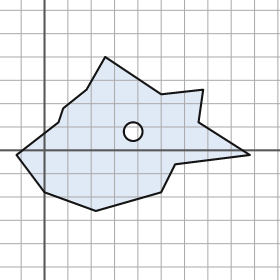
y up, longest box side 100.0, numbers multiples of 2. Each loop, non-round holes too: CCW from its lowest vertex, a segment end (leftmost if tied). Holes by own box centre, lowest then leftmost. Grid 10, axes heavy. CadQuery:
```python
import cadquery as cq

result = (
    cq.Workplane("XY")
    .moveTo(22.0, -26.0)
    .lineTo(50.0, -18.0)
    .lineTo(56.0, -6.0)
    .lineTo(88.0, -2.0)
    .lineTo(66.0, 12.0)
    .lineTo(68.0, 26.0)
    .lineTo(50.0, 24.0)
    .lineTo(26.0, 40.0)
    .lineTo(18.0, 26.0)
    .lineTo(8.0, 18.0)
    .lineTo(6.0, 12.0)
    .lineTo(-12.0, -2.0)
    .lineTo(0.0, -18.0)
    .close()
    .moveTo(38.0, 8.0)
    .circle(4.0)
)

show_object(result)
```